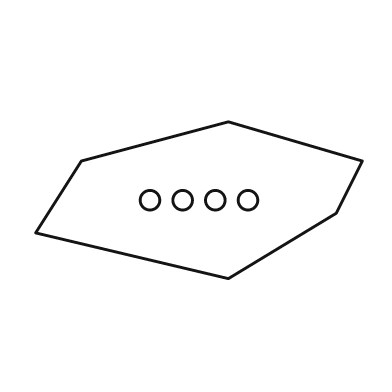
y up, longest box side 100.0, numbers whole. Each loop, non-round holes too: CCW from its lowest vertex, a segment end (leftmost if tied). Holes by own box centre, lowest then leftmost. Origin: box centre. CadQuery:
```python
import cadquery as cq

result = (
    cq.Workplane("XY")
    .moveTo(9.0, -24.0)
    .lineTo(42.0, -4.0)
    .lineTo(50.0, 12.0)
    .lineTo(9.0, 24.0)
    .lineTo(-36.0, 12.0)
    .lineTo(-50.0, -10.0)
    .close()
    .moveTo(-15.0, 0.0)
    .circle(3.0)
    .moveTo(-5.0, 0.0)
    .circle(3.0)
    .moveTo(5.0, 0.0)
    .circle(3.0)
    .moveTo(15.0, 0.0)
    .circle(3.0)
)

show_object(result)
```